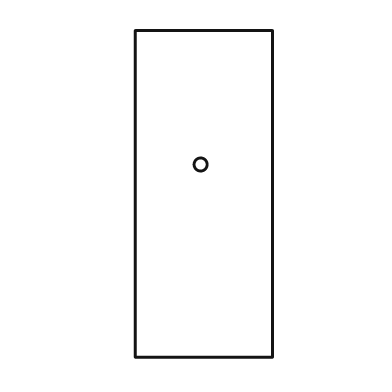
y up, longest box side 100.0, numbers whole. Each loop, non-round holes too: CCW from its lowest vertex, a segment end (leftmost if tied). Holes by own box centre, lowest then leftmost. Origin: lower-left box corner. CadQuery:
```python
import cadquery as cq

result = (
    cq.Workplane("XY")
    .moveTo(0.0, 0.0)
    .lineTo(42.0, 0.0)
    .lineTo(42.0, 100.0)
    .lineTo(0.0, 100.0)
    .close()
    .moveTo(20.0, 59.0)
    .circle(2.0)
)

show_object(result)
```